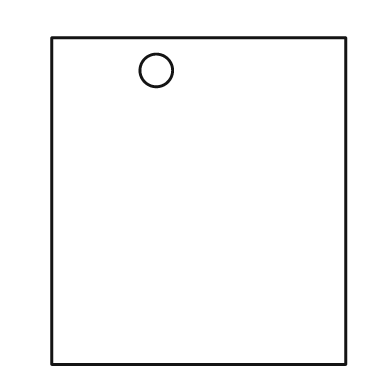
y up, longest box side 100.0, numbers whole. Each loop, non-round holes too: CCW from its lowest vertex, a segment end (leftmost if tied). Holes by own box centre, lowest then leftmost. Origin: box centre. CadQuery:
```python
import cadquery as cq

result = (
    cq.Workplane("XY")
    .moveTo(-45.0, -50.0)
    .lineTo(45.0, -50.0)
    .lineTo(45.0, 50.0)
    .lineTo(-45.0, 50.0)
    .close()
    .moveTo(-13.0, 40.0)
    .circle(5.0)
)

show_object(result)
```